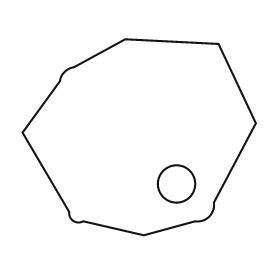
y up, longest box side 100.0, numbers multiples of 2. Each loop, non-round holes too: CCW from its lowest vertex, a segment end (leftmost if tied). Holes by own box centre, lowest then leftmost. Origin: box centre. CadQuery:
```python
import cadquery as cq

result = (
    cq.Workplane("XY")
    .moveTo(2.0, -42.0)
    .lineTo(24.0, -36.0)
    .threePointArc((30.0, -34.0), (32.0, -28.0))
    .lineTo(50.0, 6.0)
    .lineTo(34.0, 40.0)
    .lineTo(-6.0, 42.0)
    .lineTo(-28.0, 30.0)
    .threePointArc((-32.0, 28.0), (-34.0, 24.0))
    .lineTo(-50.0, 2.0)
    .lineTo(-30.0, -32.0)
    .threePointArc((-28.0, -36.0), (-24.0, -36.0))
    .close()
    .moveTo(16.0, -20.0)
    .circle(8.0)
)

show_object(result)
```